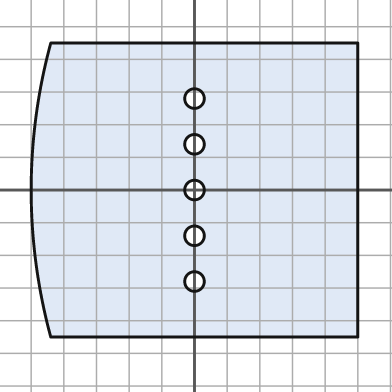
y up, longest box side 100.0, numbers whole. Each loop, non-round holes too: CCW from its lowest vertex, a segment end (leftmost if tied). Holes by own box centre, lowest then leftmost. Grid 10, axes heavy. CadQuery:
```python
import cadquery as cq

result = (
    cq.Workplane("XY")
    .moveTo(-44.0, -45.0)
    .lineTo(50.0, -45.0)
    .lineTo(50.0, 45.0)
    .lineTo(-44.0, 45.0)
    .threePointArc((-50.0, 0.0), (-44.0, -45.0))
    .close()
    .moveTo(0.0, -28.0)
    .circle(3.0)
    .moveTo(0.0, -14.0)
    .circle(3.0)
    .moveTo(0.0, 0.0)
    .circle(3.0)
    .moveTo(0.0, 14.0)
    .circle(3.0)
    .moveTo(0.0, 28.0)
    .circle(3.0)
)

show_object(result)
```